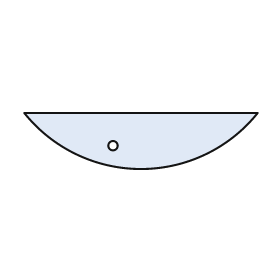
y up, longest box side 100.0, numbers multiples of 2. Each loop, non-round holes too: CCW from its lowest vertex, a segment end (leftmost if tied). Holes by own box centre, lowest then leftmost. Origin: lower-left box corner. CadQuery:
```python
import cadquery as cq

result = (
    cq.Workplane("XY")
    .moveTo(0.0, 24.0)
    .threePointArc((50.0, 0.0), (100.0, 24.0))
    .close()
    .moveTo(38.0, 10.0)
    .circle(2.0)
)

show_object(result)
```